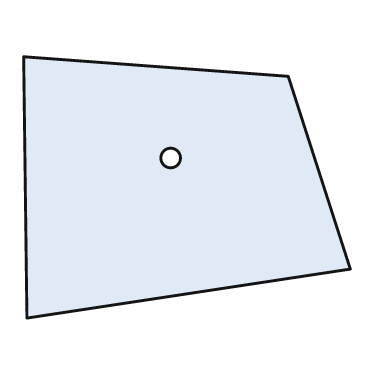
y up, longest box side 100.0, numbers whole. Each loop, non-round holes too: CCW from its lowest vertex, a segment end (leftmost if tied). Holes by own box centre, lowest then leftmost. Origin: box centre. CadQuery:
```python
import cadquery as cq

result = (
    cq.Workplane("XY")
    .moveTo(-49.0, -40.0)
    .lineTo(50.0, -25.0)
    .lineTo(31.0, 34.0)
    .lineTo(-50.0, 40.0)
    .close()
    .moveTo(-5.0, 9.0)
    .circle(3.0)
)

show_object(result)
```